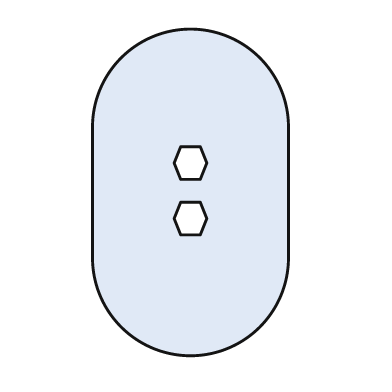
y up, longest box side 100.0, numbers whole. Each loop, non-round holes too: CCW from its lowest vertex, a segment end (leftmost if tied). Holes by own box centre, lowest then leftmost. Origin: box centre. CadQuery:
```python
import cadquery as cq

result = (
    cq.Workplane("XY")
    .moveTo(-30.0, -20.0)
    .threePointArc((0.0, -50.0), (30.0, -20.0))
    .lineTo(30.0, 20.0)
    .threePointArc((0.0, 50.0), (-30.0, 20.0))
    .close()
    .moveTo(-3.0, -13.0)
    .lineTo(3.0, -13.0)
    .lineTo(5.0, -8.0)
    .lineTo(3.0, -3.0)
    .lineTo(-3.0, -3.0)
    .lineTo(-5.0, -8.0)
    .close()
    .moveTo(-3.0, 4.0)
    .lineTo(3.0, 4.0)
    .lineTo(5.0, 9.0)
    .lineTo(3.0, 14.0)
    .lineTo(-3.0, 14.0)
    .lineTo(-5.0, 9.0)
    .close()
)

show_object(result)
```